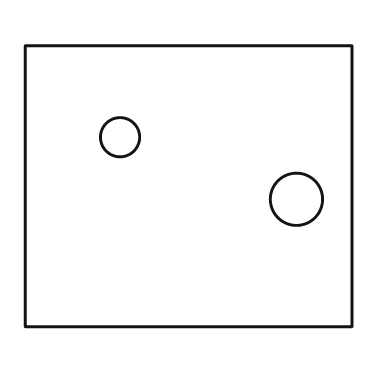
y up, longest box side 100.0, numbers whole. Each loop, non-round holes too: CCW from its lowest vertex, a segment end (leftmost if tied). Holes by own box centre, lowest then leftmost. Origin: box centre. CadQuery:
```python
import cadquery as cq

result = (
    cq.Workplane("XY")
    .moveTo(-50.0, -43.0)
    .lineTo(50.0, -43.0)
    .lineTo(50.0, 43.0)
    .lineTo(-50.0, 43.0)
    .close()
    .moveTo(33.0, -4.0)
    .circle(8.0)
    .moveTo(-21.0, 15.0)
    .circle(6.0)
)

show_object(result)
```